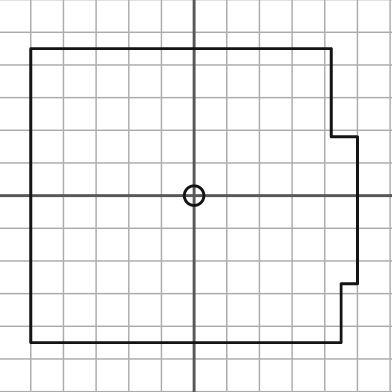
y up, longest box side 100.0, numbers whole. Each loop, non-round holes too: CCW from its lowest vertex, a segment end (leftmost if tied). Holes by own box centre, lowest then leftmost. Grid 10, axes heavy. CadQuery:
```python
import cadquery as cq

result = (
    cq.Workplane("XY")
    .moveTo(-50.0, -45.0)
    .lineTo(45.0, -45.0)
    .lineTo(45.0, -27.0)
    .lineTo(50.0, -27.0)
    .lineTo(50.0, 18.0)
    .lineTo(42.0, 18.0)
    .lineTo(42.0, 45.0)
    .lineTo(-50.0, 45.0)
    .close()
    .moveTo(0.0, 0.0)
    .circle(3.0)
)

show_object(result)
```